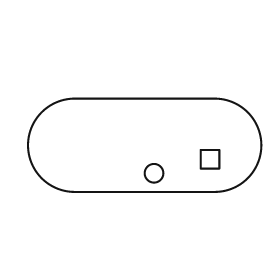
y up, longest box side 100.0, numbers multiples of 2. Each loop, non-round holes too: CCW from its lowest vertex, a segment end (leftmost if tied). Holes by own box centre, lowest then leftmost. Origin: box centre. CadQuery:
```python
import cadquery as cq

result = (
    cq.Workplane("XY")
    .moveTo(-30.0, -20.0)
    .lineTo(30.0, -20.0)
    .threePointArc((50.0, 0.0), (30.0, 20.0))
    .lineTo(-30.0, 20.0)
    .threePointArc((-50.0, 0.0), (-30.0, -20.0))
    .close()
    .moveTo(4.0, -12.0)
    .circle(4.0)
    .moveTo(24.0, -10.0)
    .lineTo(32.0, -10.0)
    .lineTo(32.0, -2.0)
    .lineTo(24.0, -2.0)
    .close()
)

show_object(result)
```